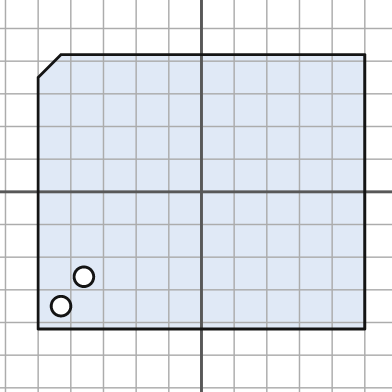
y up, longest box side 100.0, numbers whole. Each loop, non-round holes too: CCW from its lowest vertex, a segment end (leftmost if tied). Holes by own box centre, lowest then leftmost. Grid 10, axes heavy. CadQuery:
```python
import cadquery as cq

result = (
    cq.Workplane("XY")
    .moveTo(-50.0, -42.0)
    .lineTo(50.0, -42.0)
    .lineTo(50.0, 42.0)
    .lineTo(-43.0, 42.0)
    .lineTo(-50.0, 35.0)
    .close()
    .moveTo(-43.0, -35.0)
    .circle(3.0)
    .moveTo(-36.0, -26.0)
    .circle(3.0)
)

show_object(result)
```